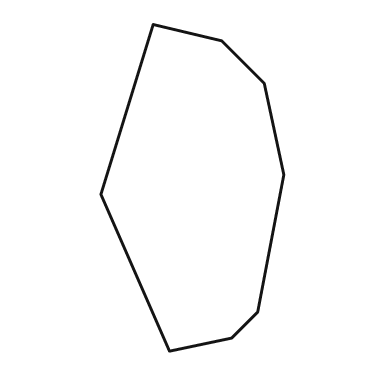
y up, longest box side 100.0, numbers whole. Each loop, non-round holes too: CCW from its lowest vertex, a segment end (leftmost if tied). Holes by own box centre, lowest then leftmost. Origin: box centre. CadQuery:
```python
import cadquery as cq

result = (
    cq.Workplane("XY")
    .moveTo(-7.0, -50.0)
    .lineTo(12.0, -46.0)
    .lineTo(20.0, -38.0)
    .lineTo(28.0, 4.0)
    .lineTo(22.0, 32.0)
    .lineTo(9.0, 45.0)
    .lineTo(-12.0, 50.0)
    .lineTo(-28.0, -2.0)
    .close()
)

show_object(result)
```